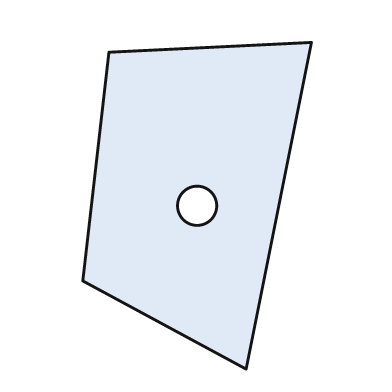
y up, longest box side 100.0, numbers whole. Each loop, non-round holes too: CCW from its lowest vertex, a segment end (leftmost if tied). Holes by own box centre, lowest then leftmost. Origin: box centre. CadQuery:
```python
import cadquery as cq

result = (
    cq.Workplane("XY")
    .moveTo(15.0, -50.0)
    .lineTo(35.0, 50.0)
    .lineTo(-27.0, 47.0)
    .lineTo(-35.0, -23.0)
    .close()
    .moveTo(0.0, 0.0)
    .circle(6.0)
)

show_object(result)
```